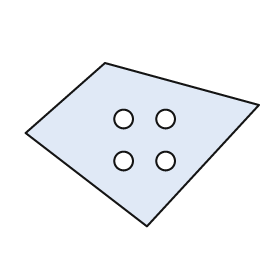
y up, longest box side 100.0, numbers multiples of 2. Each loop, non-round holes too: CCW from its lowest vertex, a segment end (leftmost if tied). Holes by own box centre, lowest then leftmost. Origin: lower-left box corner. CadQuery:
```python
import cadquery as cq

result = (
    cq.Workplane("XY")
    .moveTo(52.0, 0.0)
    .lineTo(100.0, 52.0)
    .lineTo(34.0, 70.0)
    .lineTo(0.0, 40.0)
    .close()
    .moveTo(42.0, 28.0)
    .circle(4.0)
    .moveTo(60.0, 28.0)
    .circle(4.0)
    .moveTo(42.0, 46.0)
    .circle(4.0)
    .moveTo(60.0, 46.0)
    .circle(4.0)
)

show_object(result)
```